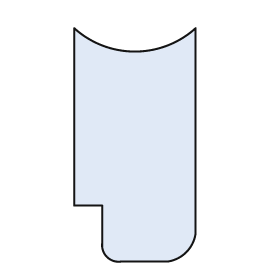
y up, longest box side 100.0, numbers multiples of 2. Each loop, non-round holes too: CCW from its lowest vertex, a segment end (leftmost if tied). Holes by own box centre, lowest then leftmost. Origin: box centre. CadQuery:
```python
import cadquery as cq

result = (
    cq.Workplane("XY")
    .moveTo(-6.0, -50.0)
    .lineTo(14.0, -50.0)
    .threePointArc((22.0, -46.0), (26.0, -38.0))
    .lineTo(26.0, 50.0)
    .threePointArc((0.0, 40.0), (-26.0, 50.0))
    .lineTo(-26.0, -26.0)
    .lineTo(-14.0, -26.0)
    .lineTo(-14.0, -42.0)
    .threePointArc((-12.0, -48.0), (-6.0, -50.0))
    .close()
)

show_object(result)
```